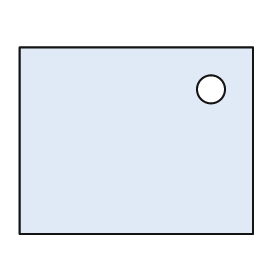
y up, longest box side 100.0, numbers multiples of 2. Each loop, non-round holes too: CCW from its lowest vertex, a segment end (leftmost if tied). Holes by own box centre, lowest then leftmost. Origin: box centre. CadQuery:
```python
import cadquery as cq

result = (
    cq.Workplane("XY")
    .moveTo(-50.0, -40.0)
    .lineTo(50.0, -40.0)
    .lineTo(50.0, 40.0)
    .lineTo(-50.0, 40.0)
    .close()
    .moveTo(32.0, 22.0)
    .circle(6.0)
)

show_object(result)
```